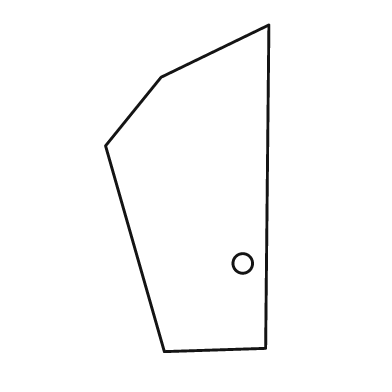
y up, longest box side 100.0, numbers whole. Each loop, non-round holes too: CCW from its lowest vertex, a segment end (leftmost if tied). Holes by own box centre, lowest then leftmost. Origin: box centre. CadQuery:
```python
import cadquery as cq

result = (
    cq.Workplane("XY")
    .moveTo(-7.0, -50.0)
    .lineTo(24.0, -49.0)
    .lineTo(25.0, 50.0)
    .lineTo(-8.0, 34.0)
    .lineTo(-25.0, 13.0)
    .close()
    .moveTo(17.0, -23.0)
    .circle(3.0)
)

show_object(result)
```